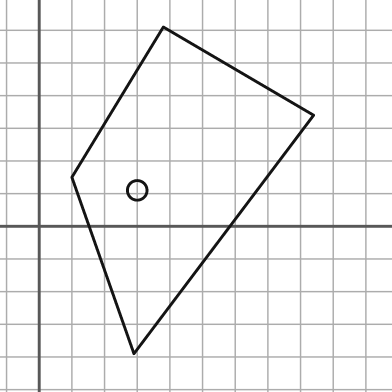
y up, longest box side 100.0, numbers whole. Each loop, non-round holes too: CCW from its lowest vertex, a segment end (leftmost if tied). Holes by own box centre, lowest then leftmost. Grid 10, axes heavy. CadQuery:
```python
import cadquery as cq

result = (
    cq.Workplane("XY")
    .moveTo(29.0, -39.0)
    .lineTo(84.0, 34.0)
    .lineTo(38.0, 61.0)
    .lineTo(10.0, 15.0)
    .close()
    .moveTo(30.0, 11.0)
    .circle(3.0)
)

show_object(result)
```